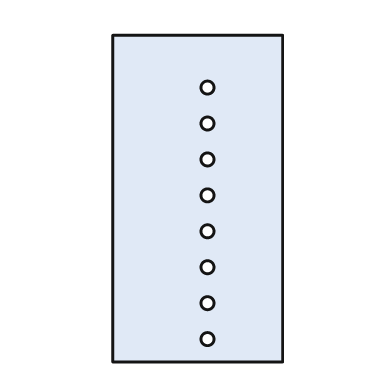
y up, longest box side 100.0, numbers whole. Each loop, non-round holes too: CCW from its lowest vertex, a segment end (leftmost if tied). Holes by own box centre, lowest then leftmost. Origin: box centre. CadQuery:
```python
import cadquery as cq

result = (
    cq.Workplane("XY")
    .moveTo(-26.0, -50.0)
    .lineTo(26.0, -50.0)
    .lineTo(26.0, 50.0)
    .lineTo(-26.0, 50.0)
    .close()
    .moveTo(3.0, -43.0)
    .circle(2.0)
    .moveTo(3.0, -32.0)
    .circle(2.0)
    .moveTo(3.0, -21.0)
    .circle(2.0)
    .moveTo(3.0, -10.0)
    .circle(2.0)
    .moveTo(3.0, 1.0)
    .circle(2.0)
    .moveTo(3.0, 12.0)
    .circle(2.0)
    .moveTo(3.0, 23.0)
    .circle(2.0)
    .moveTo(3.0, 34.0)
    .circle(2.0)
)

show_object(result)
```